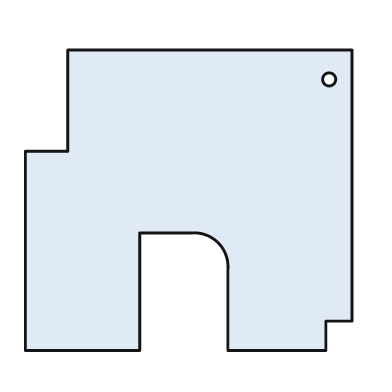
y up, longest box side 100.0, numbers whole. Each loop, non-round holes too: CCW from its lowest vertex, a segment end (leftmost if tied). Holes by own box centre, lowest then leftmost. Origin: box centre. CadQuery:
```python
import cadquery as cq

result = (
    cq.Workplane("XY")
    .moveTo(-50.0, -46.0)
    .lineTo(-15.0, -46.0)
    .lineTo(-15.0, -10.0)
    .lineTo(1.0, -10.0)
    .threePointArc((9.0, -13.0), (12.0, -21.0))
    .lineTo(12.0, -46.0)
    .lineTo(42.0, -46.0)
    .lineTo(42.0, -37.0)
    .lineTo(50.0, -37.0)
    .lineTo(50.0, 46.0)
    .lineTo(-37.0, 46.0)
    .lineTo(-37.0, 15.0)
    .lineTo(-50.0, 15.0)
    .close()
    .moveTo(43.0, 37.0)
    .circle(2.0)
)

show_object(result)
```